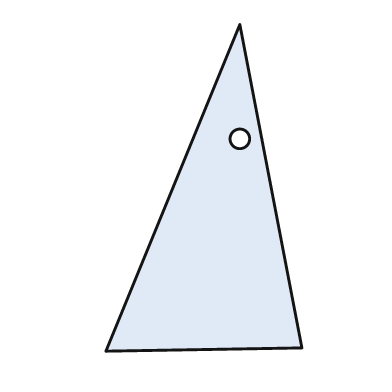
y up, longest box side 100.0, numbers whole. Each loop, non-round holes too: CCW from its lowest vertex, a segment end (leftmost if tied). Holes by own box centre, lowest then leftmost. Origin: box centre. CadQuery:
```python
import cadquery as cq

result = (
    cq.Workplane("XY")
    .moveTo(-30.0, -50.0)
    .lineTo(30.0, -49.0)
    .lineTo(11.0, 50.0)
    .close()
    .moveTo(11.0, 15.0)
    .circle(3.0)
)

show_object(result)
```